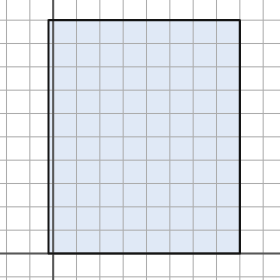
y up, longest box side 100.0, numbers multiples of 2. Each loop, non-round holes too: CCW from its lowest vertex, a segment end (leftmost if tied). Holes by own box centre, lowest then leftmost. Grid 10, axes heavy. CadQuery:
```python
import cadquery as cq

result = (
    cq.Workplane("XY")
    .moveTo(-2.0, 0.0)
    .lineTo(80.0, 0.0)
    .lineTo(80.0, 100.0)
    .lineTo(-2.0, 100.0)
    .close()
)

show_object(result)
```